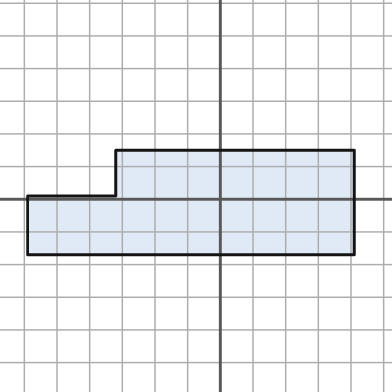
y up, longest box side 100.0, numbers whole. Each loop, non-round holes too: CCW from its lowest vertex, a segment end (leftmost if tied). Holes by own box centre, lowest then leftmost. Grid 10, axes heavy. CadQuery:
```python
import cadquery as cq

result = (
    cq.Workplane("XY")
    .moveTo(-59.0, -17.0)
    .lineTo(41.0, -17.0)
    .lineTo(41.0, 15.0)
    .lineTo(-32.0, 15.0)
    .lineTo(-32.0, 1.0)
    .lineTo(-59.0, 1.0)
    .close()
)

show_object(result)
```